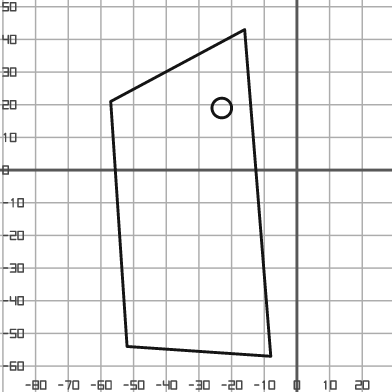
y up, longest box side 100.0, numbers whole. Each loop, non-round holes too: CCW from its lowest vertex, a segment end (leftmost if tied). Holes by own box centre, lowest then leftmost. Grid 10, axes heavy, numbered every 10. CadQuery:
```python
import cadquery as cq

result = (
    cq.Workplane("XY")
    .moveTo(-8.0, -57.0)
    .lineTo(-16.0, 43.0)
    .lineTo(-57.0, 21.0)
    .lineTo(-52.0, -54.0)
    .close()
    .moveTo(-23.0, 19.0)
    .circle(3.0)
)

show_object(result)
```